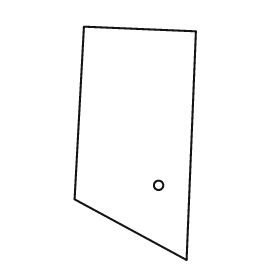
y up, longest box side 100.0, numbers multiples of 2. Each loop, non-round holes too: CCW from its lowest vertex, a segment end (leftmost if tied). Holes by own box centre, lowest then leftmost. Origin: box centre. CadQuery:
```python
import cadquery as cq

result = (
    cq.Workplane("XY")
    .moveTo(22.0, -50.0)
    .lineTo(26.0, 48.0)
    .lineTo(-22.0, 50.0)
    .lineTo(-26.0, -24.0)
    .close()
    .moveTo(10.0, -18.0)
    .circle(2.0)
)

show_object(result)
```